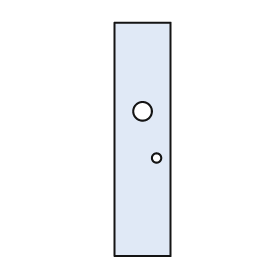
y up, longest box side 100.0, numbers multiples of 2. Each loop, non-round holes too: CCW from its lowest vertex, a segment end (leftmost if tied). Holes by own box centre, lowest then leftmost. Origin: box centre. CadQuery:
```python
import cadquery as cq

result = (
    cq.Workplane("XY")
    .moveTo(-12.0, -50.0)
    .lineTo(12.0, -50.0)
    .lineTo(12.0, 50.0)
    .lineTo(-12.0, 50.0)
    .close()
    .moveTo(6.0, -8.0)
    .circle(2.0)
    .moveTo(0.0, 12.0)
    .circle(4.0)
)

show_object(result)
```